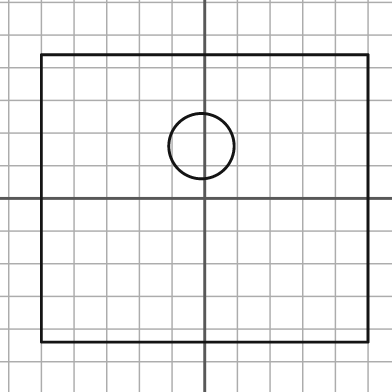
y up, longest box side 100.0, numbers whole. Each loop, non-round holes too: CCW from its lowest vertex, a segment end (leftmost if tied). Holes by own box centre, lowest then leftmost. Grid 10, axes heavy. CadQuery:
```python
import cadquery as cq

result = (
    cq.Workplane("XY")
    .moveTo(-50.0, -44.0)
    .lineTo(50.0, -44.0)
    .lineTo(50.0, 44.0)
    .lineTo(-50.0, 44.0)
    .close()
    .moveTo(-1.0, 16.0)
    .circle(10.0)
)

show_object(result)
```